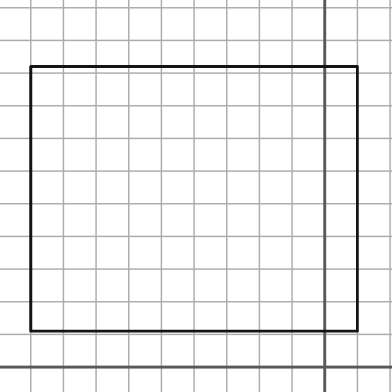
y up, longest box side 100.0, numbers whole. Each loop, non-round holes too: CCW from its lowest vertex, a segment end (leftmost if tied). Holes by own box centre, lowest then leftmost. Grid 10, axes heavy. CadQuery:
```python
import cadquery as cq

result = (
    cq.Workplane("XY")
    .moveTo(-90.0, 11.0)
    .lineTo(10.0, 11.0)
    .lineTo(10.0, 92.0)
    .lineTo(-90.0, 92.0)
    .close()
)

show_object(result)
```